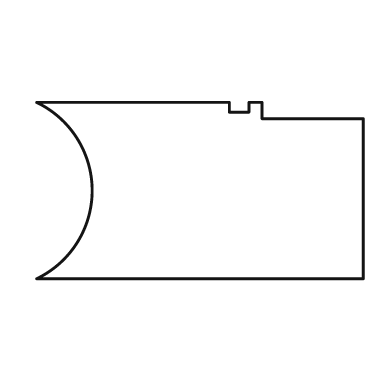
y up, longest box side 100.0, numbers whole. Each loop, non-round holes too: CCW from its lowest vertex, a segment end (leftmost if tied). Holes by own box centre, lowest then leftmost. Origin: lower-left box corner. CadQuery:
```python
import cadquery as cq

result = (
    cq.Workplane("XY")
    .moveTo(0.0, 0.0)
    .lineTo(100.0, 0.0)
    .lineTo(100.0, 49.0)
    .lineTo(69.0, 49.0)
    .lineTo(69.0, 54.0)
    .lineTo(65.0, 54.0)
    .lineTo(65.0, 51.0)
    .lineTo(59.0, 51.0)
    .lineTo(59.0, 54.0)
    .lineTo(0.0, 54.0)
    .threePointArc((17.0, 27.0), (0.0, 0.0))
    .close()
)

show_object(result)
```